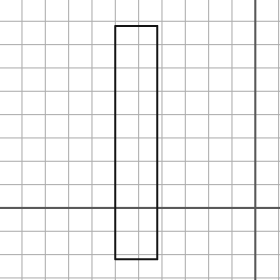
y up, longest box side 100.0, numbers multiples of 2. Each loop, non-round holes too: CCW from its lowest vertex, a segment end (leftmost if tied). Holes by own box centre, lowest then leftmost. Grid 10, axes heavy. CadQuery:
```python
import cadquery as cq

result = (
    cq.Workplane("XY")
    .moveTo(-60.0, -22.0)
    .lineTo(-42.0, -22.0)
    .lineTo(-42.0, 78.0)
    .lineTo(-60.0, 78.0)
    .close()
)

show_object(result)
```